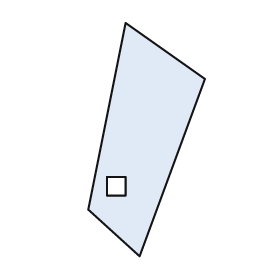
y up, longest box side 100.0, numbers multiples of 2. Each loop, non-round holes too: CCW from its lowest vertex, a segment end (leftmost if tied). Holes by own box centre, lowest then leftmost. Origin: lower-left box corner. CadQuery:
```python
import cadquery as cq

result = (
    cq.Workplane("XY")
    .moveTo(22.0, 0.0)
    .lineTo(50.0, 76.0)
    .lineTo(16.0, 100.0)
    .lineTo(0.0, 20.0)
    .close()
    .moveTo(8.0, 26.0)
    .lineTo(16.0, 26.0)
    .lineTo(16.0, 34.0)
    .lineTo(8.0, 34.0)
    .close()
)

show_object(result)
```